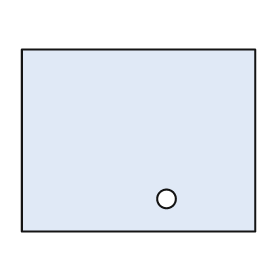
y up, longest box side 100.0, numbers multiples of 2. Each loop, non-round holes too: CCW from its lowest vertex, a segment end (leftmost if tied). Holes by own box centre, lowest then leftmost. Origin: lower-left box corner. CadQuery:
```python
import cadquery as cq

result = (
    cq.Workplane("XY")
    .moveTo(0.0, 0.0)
    .lineTo(100.0, 0.0)
    .lineTo(100.0, 78.0)
    .lineTo(0.0, 78.0)
    .close()
    .moveTo(62.0, 14.0)
    .circle(4.0)
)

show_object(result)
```